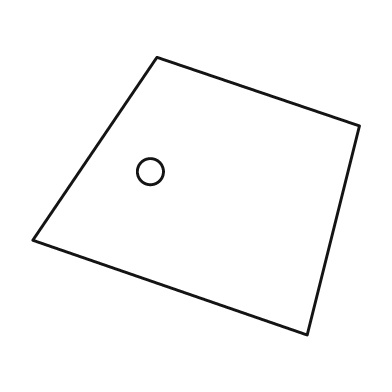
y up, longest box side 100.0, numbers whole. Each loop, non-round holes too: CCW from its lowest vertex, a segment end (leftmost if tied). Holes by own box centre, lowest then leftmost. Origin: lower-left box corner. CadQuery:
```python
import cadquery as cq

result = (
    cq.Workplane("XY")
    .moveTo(84.0, 0.0)
    .lineTo(100.0, 64.0)
    .lineTo(38.0, 85.0)
    .lineTo(0.0, 29.0)
    .close()
    .moveTo(36.0, 50.0)
    .circle(4.0)
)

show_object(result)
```